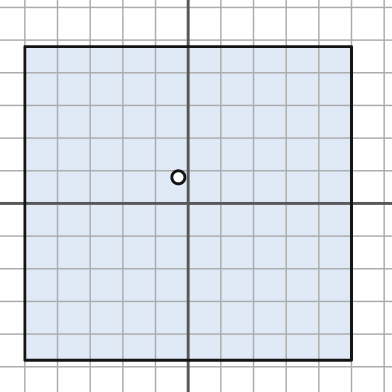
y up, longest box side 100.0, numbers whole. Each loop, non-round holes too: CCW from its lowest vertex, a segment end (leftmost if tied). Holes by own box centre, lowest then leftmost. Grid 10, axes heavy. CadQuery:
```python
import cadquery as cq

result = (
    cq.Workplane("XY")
    .moveTo(-50.0, -48.0)
    .lineTo(50.0, -48.0)
    .lineTo(50.0, 48.0)
    .lineTo(-50.0, 48.0)
    .close()
    .moveTo(-3.0, 8.0)
    .circle(2.0)
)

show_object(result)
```